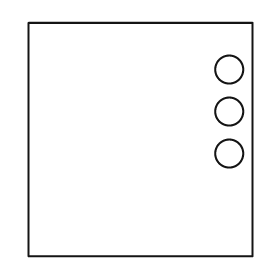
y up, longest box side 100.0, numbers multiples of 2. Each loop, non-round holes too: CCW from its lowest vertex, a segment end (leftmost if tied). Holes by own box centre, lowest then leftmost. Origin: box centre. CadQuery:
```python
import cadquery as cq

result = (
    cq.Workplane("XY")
    .moveTo(-48.0, -50.0)
    .lineTo(48.0, -50.0)
    .lineTo(48.0, 50.0)
    .lineTo(-48.0, 50.0)
    .close()
    .moveTo(38.0, -6.0)
    .circle(6.0)
    .moveTo(38.0, 12.0)
    .circle(6.0)
    .moveTo(38.0, 30.0)
    .circle(6.0)
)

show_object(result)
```